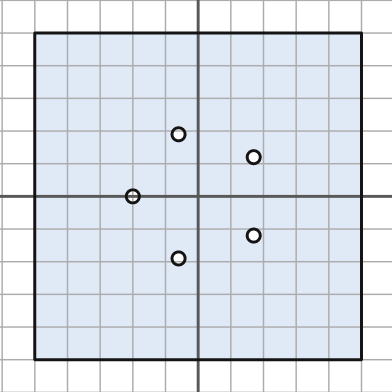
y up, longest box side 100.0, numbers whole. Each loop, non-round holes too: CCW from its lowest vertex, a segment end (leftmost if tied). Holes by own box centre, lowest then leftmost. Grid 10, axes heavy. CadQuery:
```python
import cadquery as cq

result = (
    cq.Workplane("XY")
    .moveTo(-50.0, -50.0)
    .lineTo(50.0, -50.0)
    .lineTo(50.0, 50.0)
    .lineTo(-50.0, 50.0)
    .close()
    .moveTo(-6.0, -19.0)
    .circle(2.0)
    .moveTo(17.0, -12.0)
    .circle(2.0)
    .moveTo(-20.0, 0.0)
    .circle(2.0)
    .moveTo(17.0, 12.0)
    .circle(2.0)
    .moveTo(-6.0, 19.0)
    .circle(2.0)
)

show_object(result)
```